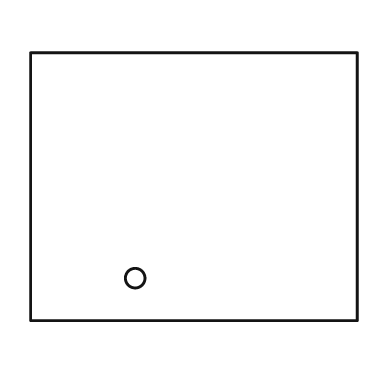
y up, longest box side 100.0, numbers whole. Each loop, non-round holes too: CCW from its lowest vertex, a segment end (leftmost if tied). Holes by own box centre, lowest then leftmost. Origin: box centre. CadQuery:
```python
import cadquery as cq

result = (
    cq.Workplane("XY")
    .moveTo(-50.0, -41.0)
    .lineTo(50.0, -41.0)
    .lineTo(50.0, 41.0)
    .lineTo(-50.0, 41.0)
    .close()
    .moveTo(-18.0, -28.0)
    .circle(3.0)
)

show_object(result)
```